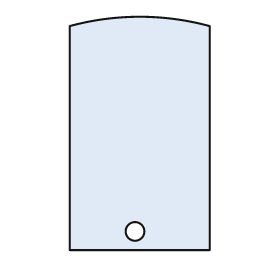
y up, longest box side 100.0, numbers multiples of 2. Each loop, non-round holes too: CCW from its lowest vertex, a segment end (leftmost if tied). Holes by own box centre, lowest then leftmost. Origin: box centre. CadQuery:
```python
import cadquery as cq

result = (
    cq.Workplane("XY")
    .moveTo(-30.0, -50.0)
    .lineTo(30.0, -50.0)
    .lineTo(30.0, 46.0)
    .threePointArc((0.0, 50.0), (-30.0, 46.0))
    .close()
    .moveTo(-2.0, -42.0)
    .circle(4.0)
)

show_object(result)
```